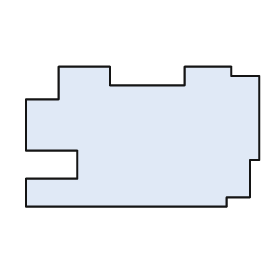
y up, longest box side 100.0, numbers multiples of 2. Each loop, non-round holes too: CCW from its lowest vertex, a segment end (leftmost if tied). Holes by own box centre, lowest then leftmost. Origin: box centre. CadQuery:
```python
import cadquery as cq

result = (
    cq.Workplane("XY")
    .moveTo(-50.0, -30.0)
    .lineTo(36.0, -30.0)
    .lineTo(36.0, -26.0)
    .lineTo(46.0, -26.0)
    .lineTo(46.0, -10.0)
    .lineTo(50.0, -10.0)
    .lineTo(50.0, 26.0)
    .lineTo(38.0, 26.0)
    .lineTo(38.0, 30.0)
    .lineTo(18.0, 30.0)
    .lineTo(18.0, 22.0)
    .lineTo(-14.0, 22.0)
    .lineTo(-14.0, 30.0)
    .lineTo(-36.0, 30.0)
    .lineTo(-36.0, 16.0)
    .lineTo(-50.0, 16.0)
    .lineTo(-50.0, -6.0)
    .lineTo(-28.0, -6.0)
    .lineTo(-28.0, -18.0)
    .lineTo(-50.0, -18.0)
    .close()
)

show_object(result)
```